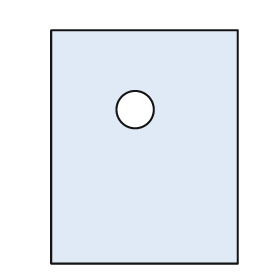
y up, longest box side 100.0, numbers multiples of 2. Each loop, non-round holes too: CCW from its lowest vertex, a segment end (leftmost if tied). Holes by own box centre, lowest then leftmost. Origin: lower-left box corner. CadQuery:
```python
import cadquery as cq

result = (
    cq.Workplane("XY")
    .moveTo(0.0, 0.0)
    .lineTo(80.0, 0.0)
    .lineTo(80.0, 100.0)
    .lineTo(0.0, 100.0)
    .close()
    .moveTo(36.0, 66.0)
    .circle(8.0)
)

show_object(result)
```